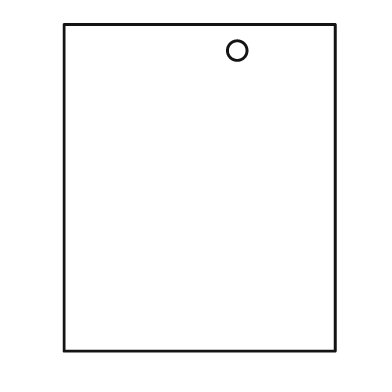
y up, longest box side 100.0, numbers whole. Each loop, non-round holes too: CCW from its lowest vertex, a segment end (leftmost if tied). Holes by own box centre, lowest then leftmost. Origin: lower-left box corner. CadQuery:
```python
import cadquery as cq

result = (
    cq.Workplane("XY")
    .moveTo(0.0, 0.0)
    .lineTo(83.0, 0.0)
    .lineTo(83.0, 100.0)
    .lineTo(0.0, 100.0)
    .close()
    .moveTo(53.0, 92.0)
    .circle(3.0)
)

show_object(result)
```